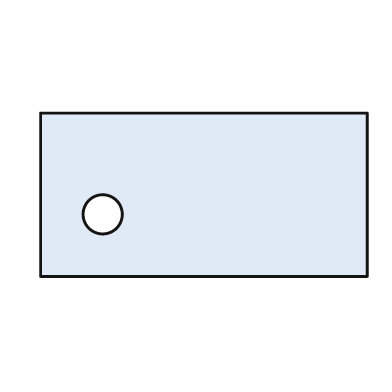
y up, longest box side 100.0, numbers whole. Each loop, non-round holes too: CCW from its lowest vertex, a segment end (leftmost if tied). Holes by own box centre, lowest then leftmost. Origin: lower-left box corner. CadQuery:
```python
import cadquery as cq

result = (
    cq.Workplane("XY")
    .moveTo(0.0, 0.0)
    .lineTo(100.0, 0.0)
    .lineTo(100.0, 50.0)
    .lineTo(0.0, 50.0)
    .close()
    .moveTo(19.0, 19.0)
    .circle(6.0)
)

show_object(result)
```